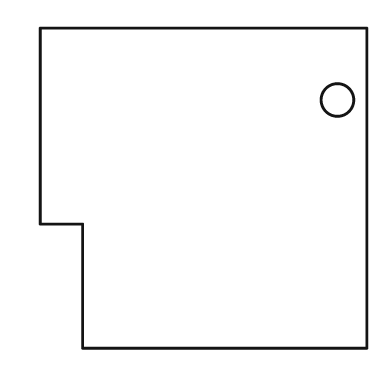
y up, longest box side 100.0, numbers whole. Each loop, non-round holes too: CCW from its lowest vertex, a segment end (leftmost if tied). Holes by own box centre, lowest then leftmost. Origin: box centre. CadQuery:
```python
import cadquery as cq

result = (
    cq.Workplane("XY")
    .moveTo(-37.0, -49.0)
    .lineTo(50.0, -49.0)
    .lineTo(50.0, 49.0)
    .lineTo(-50.0, 49.0)
    .lineTo(-50.0, -11.0)
    .lineTo(-37.0, -11.0)
    .close()
    .moveTo(41.0, 27.0)
    .circle(5.0)
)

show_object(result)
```